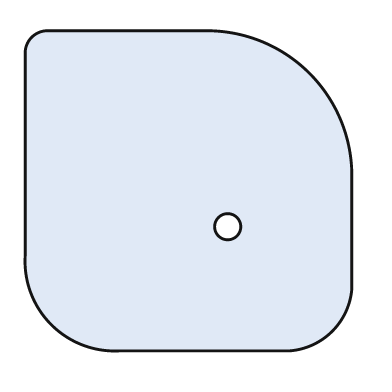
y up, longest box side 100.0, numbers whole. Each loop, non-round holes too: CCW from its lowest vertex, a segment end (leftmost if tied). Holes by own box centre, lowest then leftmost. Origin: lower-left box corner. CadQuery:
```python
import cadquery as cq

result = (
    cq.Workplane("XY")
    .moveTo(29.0, 0.0)
    .lineTo(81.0, 0.0)
    .threePointArc((94.0, 6.0), (100.0, 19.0))
    .lineTo(100.0, 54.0)
    .threePointArc((87.0, 85.0), (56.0, 98.0))
    .lineTo(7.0, 98.0)
    .threePointArc((2.0, 96.0), (0.0, 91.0))
    .lineTo(0.0, 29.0)
    .threePointArc((8.0, 8.0), (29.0, 0.0))
    .close()
    .moveTo(62.0, 38.0)
    .circle(4.0)
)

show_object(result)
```